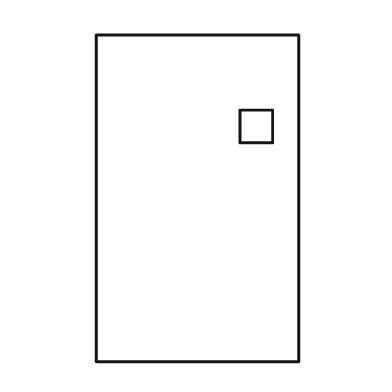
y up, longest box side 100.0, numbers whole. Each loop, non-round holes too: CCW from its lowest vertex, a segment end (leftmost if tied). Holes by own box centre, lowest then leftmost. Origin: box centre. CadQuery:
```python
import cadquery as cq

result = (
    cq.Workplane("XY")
    .moveTo(-31.0, -50.0)
    .lineTo(31.0, -50.0)
    .lineTo(31.0, 50.0)
    .lineTo(-31.0, 50.0)
    .close()
    .moveTo(13.0, 17.0)
    .lineTo(23.0, 17.0)
    .lineTo(23.0, 27.0)
    .lineTo(13.0, 27.0)
    .close()
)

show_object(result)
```